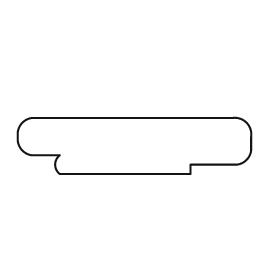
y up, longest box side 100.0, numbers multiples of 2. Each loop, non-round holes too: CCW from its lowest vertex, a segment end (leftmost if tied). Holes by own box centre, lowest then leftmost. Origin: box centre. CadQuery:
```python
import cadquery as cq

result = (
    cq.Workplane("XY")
    .moveTo(-32.0, -12.0)
    .lineTo(24.0, -12.0)
    .lineTo(24.0, -8.0)
    .lineTo(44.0, -8.0)
    .threePointArc((48.0, -6.0), (50.0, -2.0))
    .lineTo(50.0, 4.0)
    .threePointArc((48.0, 10.0), (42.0, 12.0))
    .lineTo(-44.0, 12.0)
    .threePointArc((-48.0, 10.0), (-50.0, 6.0))
    .lineTo(-50.0, 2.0)
    .threePointArc((-48.0, -2.0), (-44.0, -4.0))
    .lineTo(-32.0, -4.0)
    .threePointArc((-34.0, -8.0), (-32.0, -12.0))
    .close()
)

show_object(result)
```